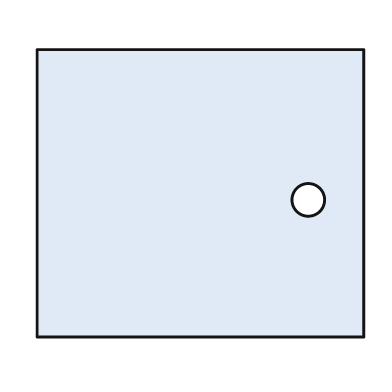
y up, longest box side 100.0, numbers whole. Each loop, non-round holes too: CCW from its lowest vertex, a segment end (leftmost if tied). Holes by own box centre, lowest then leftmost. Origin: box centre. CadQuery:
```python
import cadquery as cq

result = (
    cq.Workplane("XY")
    .moveTo(-50.0, -44.0)
    .lineTo(50.0, -44.0)
    .lineTo(50.0, 44.0)
    .lineTo(-50.0, 44.0)
    .close()
    .moveTo(33.0, -2.0)
    .circle(5.0)
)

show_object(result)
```